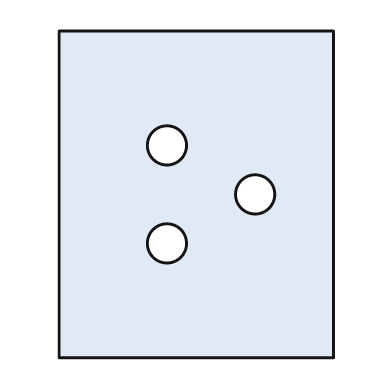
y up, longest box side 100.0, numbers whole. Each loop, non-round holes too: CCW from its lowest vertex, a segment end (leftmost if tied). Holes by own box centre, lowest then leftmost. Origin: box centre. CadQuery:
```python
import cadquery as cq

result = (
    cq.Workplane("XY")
    .moveTo(-42.0, -50.0)
    .lineTo(42.0, -50.0)
    .lineTo(42.0, 50.0)
    .lineTo(-42.0, 50.0)
    .close()
    .moveTo(-9.0, -15.0)
    .circle(6.0)
    .moveTo(18.0, 0.0)
    .circle(6.0)
    .moveTo(-9.0, 15.0)
    .circle(6.0)
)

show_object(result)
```